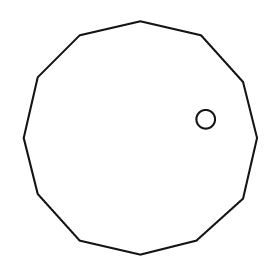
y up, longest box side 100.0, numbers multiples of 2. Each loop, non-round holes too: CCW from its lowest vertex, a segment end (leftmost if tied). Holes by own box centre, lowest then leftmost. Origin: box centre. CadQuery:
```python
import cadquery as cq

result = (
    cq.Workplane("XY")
    .moveTo(0.0, -50.0)
    .lineTo(24.0, -44.0)
    .lineTo(44.0, -26.0)
    .lineTo(50.0, 0.0)
    .lineTo(44.0, 24.0)
    .lineTo(26.0, 44.0)
    .lineTo(0.0, 50.0)
    .lineTo(-26.0, 44.0)
    .lineTo(-44.0, 26.0)
    .lineTo(-50.0, 0.0)
    .lineTo(-44.0, -24.0)
    .lineTo(-26.0, -44.0)
    .close()
    .moveTo(28.0, 8.0)
    .circle(4.0)
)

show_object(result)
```